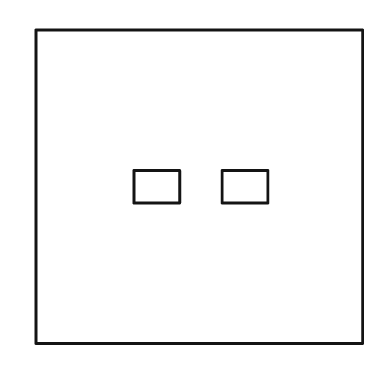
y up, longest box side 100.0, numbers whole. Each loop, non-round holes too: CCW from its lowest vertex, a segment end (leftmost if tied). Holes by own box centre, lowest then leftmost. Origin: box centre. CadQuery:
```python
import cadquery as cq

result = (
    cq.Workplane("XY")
    .moveTo(-50.0, -48.0)
    .lineTo(50.0, -48.0)
    .lineTo(50.0, 48.0)
    .lineTo(-50.0, 48.0)
    .close()
    .moveTo(-20.0, -5.0)
    .lineTo(-6.0, -5.0)
    .lineTo(-6.0, 5.0)
    .lineTo(-20.0, 5.0)
    .close()
    .moveTo(7.0, -5.0)
    .lineTo(21.0, -5.0)
    .lineTo(21.0, 5.0)
    .lineTo(7.0, 5.0)
    .close()
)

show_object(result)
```